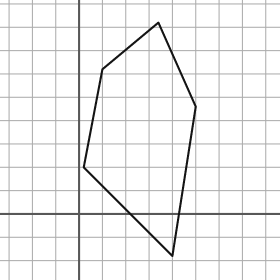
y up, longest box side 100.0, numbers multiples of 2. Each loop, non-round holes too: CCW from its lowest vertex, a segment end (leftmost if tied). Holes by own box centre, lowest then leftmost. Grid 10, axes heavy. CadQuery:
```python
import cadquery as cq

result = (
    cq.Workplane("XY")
    .moveTo(40.0, -18.0)
    .lineTo(50.0, 46.0)
    .lineTo(34.0, 82.0)
    .lineTo(10.0, 62.0)
    .lineTo(2.0, 20.0)
    .close()
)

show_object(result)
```